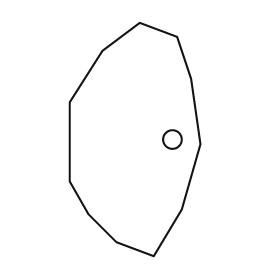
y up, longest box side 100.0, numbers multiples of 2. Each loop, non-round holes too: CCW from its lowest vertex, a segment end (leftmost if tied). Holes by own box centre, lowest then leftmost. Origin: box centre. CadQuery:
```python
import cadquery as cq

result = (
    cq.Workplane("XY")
    .moveTo(8.0, -50.0)
    .lineTo(20.0, -30.0)
    .lineTo(28.0, -2.0)
    .lineTo(24.0, 26.0)
    .lineTo(18.0, 44.0)
    .lineTo(2.0, 50.0)
    .lineTo(-14.0, 38.0)
    .lineTo(-28.0, 16.0)
    .lineTo(-28.0, -18.0)
    .lineTo(-20.0, -32.0)
    .lineTo(-8.0, -44.0)
    .close()
    .moveTo(16.0, 0.0)
    .circle(4.0)
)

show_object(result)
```